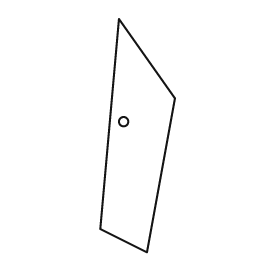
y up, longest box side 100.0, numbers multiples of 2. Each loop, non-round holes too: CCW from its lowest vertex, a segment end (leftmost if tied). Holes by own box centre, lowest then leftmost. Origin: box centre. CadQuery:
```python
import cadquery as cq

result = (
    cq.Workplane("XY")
    .moveTo(4.0, -50.0)
    .lineTo(16.0, 16.0)
    .lineTo(-8.0, 50.0)
    .lineTo(-16.0, -40.0)
    .close()
    .moveTo(-6.0, 6.0)
    .circle(2.0)
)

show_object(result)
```